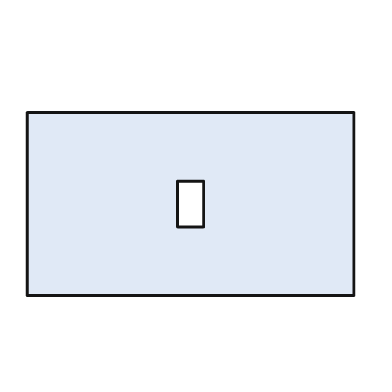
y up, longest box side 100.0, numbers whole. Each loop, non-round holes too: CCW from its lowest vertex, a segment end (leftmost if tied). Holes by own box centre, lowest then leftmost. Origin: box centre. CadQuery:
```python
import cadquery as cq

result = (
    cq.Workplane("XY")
    .moveTo(-50.0, -28.0)
    .lineTo(50.0, -28.0)
    .lineTo(50.0, 28.0)
    .lineTo(-50.0, 28.0)
    .close()
    .moveTo(-4.0, -7.0)
    .lineTo(4.0, -7.0)
    .lineTo(4.0, 7.0)
    .lineTo(-4.0, 7.0)
    .close()
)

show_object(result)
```